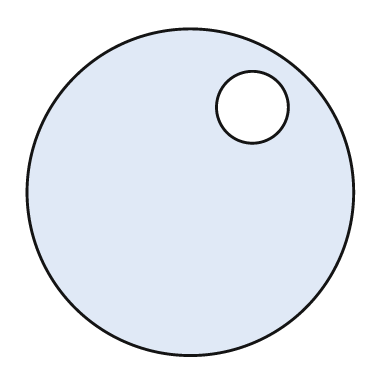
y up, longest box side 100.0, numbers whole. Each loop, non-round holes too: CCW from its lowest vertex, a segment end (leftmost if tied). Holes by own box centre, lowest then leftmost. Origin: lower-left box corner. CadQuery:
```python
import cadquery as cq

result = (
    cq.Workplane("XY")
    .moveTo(50.0, 50.0)
    .circle(50.0)
    .moveTo(69.0, 76.0)
    .circle(11.0)
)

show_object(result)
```